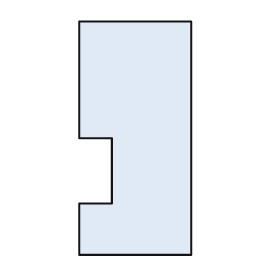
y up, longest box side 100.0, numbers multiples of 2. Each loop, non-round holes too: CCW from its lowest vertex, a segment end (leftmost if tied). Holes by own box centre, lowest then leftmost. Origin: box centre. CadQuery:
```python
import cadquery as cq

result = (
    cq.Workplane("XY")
    .moveTo(-24.0, -50.0)
    .lineTo(24.0, -50.0)
    .lineTo(24.0, 50.0)
    .lineTo(-24.0, 50.0)
    .lineTo(-24.0, 0.0)
    .lineTo(-10.0, 0.0)
    .lineTo(-10.0, -28.0)
    .lineTo(-24.0, -28.0)
    .close()
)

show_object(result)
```